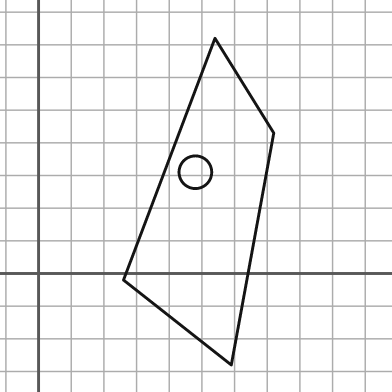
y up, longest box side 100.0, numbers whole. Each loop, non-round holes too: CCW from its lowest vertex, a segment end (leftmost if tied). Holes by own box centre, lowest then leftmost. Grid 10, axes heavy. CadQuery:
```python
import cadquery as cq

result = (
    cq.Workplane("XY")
    .moveTo(59.0, -28.0)
    .lineTo(72.0, 43.0)
    .lineTo(54.0, 72.0)
    .lineTo(26.0, -2.0)
    .close()
    .moveTo(48.0, 31.0)
    .circle(5.0)
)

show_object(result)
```